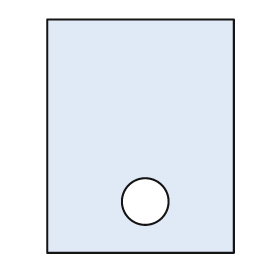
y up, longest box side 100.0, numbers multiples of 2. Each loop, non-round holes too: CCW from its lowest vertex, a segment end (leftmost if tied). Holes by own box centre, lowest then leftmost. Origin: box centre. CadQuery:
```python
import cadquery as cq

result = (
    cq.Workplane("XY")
    .moveTo(-40.0, -50.0)
    .lineTo(40.0, -50.0)
    .lineTo(40.0, 50.0)
    .lineTo(-40.0, 50.0)
    .close()
    .moveTo(2.0, -28.0)
    .circle(10.0)
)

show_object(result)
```